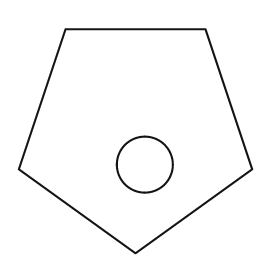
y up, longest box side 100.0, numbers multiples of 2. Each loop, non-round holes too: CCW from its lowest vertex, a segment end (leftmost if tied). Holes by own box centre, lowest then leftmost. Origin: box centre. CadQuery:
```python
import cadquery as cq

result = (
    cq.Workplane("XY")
    .moveTo(0.0, -48.0)
    .lineTo(50.0, -12.0)
    .lineTo(30.0, 48.0)
    .lineTo(-30.0, 48.0)
    .lineTo(-50.0, -12.0)
    .close()
    .moveTo(4.0, -10.0)
    .circle(12.0)
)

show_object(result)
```